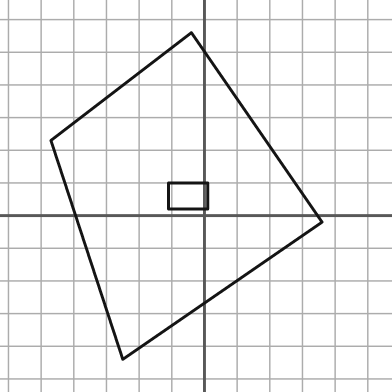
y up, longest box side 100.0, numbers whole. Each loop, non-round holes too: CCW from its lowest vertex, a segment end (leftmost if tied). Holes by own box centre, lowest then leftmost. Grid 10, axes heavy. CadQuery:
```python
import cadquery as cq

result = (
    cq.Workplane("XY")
    .moveTo(-25.0, -44.0)
    .lineTo(36.0, -2.0)
    .lineTo(-4.0, 56.0)
    .lineTo(-47.0, 23.0)
    .close()
    .moveTo(-11.0, 2.0)
    .lineTo(1.0, 2.0)
    .lineTo(1.0, 10.0)
    .lineTo(-11.0, 10.0)
    .close()
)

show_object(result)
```